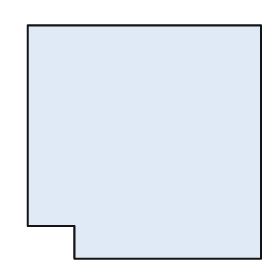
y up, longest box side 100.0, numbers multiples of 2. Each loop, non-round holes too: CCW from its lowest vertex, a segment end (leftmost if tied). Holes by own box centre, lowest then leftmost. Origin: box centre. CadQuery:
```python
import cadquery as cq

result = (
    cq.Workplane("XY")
    .moveTo(-30.0, -50.0)
    .lineTo(50.0, -50.0)
    .lineTo(50.0, 50.0)
    .lineTo(-50.0, 50.0)
    .lineTo(-50.0, -36.0)
    .lineTo(-30.0, -36.0)
    .close()
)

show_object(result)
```